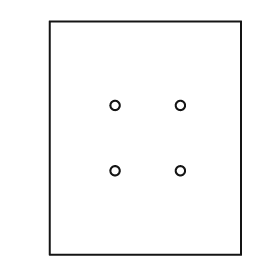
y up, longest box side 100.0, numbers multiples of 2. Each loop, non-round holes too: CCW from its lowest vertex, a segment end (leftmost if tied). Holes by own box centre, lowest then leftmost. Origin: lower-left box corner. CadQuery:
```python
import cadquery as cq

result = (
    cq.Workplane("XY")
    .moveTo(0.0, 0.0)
    .lineTo(82.0, 0.0)
    .lineTo(82.0, 100.0)
    .lineTo(0.0, 100.0)
    .close()
    .moveTo(28.0, 36.0)
    .circle(2.0)
    .moveTo(56.0, 36.0)
    .circle(2.0)
    .moveTo(28.0, 64.0)
    .circle(2.0)
    .moveTo(56.0, 64.0)
    .circle(2.0)
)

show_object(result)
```